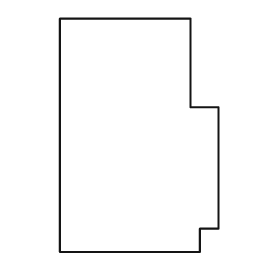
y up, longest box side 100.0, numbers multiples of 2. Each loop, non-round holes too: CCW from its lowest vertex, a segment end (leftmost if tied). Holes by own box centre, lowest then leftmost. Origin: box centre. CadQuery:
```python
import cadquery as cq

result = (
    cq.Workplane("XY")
    .moveTo(-34.0, -50.0)
    .lineTo(26.0, -50.0)
    .lineTo(26.0, -40.0)
    .lineTo(34.0, -40.0)
    .lineTo(34.0, 12.0)
    .lineTo(22.0, 12.0)
    .lineTo(22.0, 50.0)
    .lineTo(-34.0, 50.0)
    .close()
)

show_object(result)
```